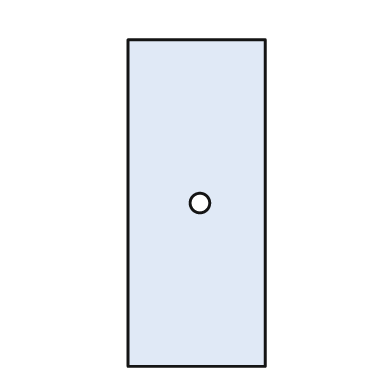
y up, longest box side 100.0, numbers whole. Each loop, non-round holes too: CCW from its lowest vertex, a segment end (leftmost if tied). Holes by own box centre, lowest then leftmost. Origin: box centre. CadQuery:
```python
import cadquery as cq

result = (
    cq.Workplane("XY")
    .moveTo(-21.0, -50.0)
    .lineTo(21.0, -50.0)
    .lineTo(21.0, 50.0)
    .lineTo(-21.0, 50.0)
    .close()
    .moveTo(1.0, 0.0)
    .circle(3.0)
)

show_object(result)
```